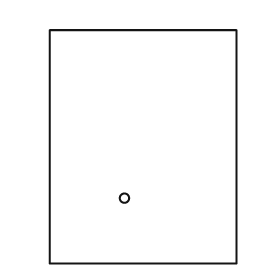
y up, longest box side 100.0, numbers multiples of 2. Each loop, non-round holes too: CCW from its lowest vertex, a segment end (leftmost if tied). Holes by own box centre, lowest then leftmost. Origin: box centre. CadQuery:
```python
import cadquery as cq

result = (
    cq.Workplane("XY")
    .moveTo(-40.0, -50.0)
    .lineTo(40.0, -50.0)
    .lineTo(40.0, 50.0)
    .lineTo(-40.0, 50.0)
    .close()
    .moveTo(-8.0, -22.0)
    .circle(2.0)
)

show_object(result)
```